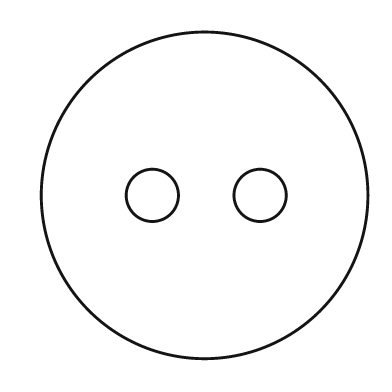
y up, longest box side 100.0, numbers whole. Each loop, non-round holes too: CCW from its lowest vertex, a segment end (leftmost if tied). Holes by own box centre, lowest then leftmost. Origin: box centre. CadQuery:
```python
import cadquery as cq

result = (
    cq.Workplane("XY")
    .moveTo(0.0, 0.0)
    .circle(50.0)
    .moveTo(-16.0, 0.0)
    .circle(8.0)
    .moveTo(17.0, 0.0)
    .circle(8.0)
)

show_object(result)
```